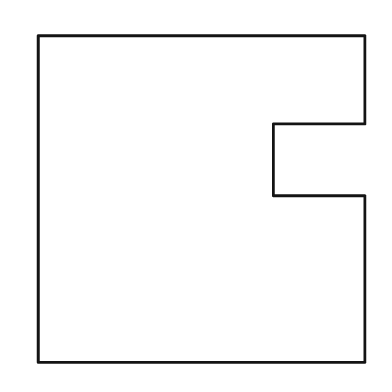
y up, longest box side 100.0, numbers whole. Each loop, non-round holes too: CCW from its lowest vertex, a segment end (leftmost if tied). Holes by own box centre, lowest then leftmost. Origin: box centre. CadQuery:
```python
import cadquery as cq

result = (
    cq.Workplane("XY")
    .moveTo(-50.0, -50.0)
    .lineTo(50.0, -50.0)
    .lineTo(50.0, 1.0)
    .lineTo(22.0, 1.0)
    .lineTo(22.0, 23.0)
    .lineTo(50.0, 23.0)
    .lineTo(50.0, 50.0)
    .lineTo(-50.0, 50.0)
    .close()
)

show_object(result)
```